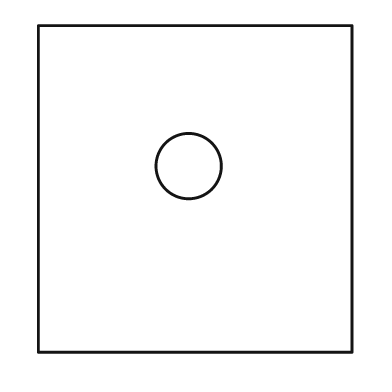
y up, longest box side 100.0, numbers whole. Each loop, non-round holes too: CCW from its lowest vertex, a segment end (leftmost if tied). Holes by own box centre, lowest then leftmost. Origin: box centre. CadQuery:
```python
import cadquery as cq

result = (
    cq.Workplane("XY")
    .moveTo(-48.0, -50.0)
    .lineTo(48.0, -50.0)
    .lineTo(48.0, 50.0)
    .lineTo(-48.0, 50.0)
    .close()
    .moveTo(-2.0, 7.0)
    .circle(10.0)
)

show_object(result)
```